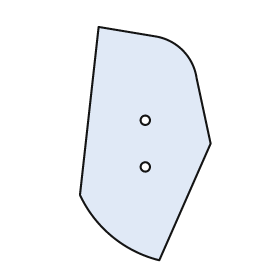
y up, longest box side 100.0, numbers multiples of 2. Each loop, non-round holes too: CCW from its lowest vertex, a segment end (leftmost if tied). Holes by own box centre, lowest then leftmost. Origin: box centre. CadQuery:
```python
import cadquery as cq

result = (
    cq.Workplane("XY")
    .moveTo(6.0, -50.0)
    .lineTo(28.0, 0.0)
    .lineTo(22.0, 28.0)
    .threePointArc((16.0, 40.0), (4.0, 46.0))
    .lineTo(-20.0, 50.0)
    .lineTo(-28.0, -22.0)
    .threePointArc((-14.0, -40.0), (6.0, -50.0))
    .close()
    .moveTo(0.0, -10.0)
    .circle(2.0)
    .moveTo(0.0, 10.0)
    .circle(2.0)
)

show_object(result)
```